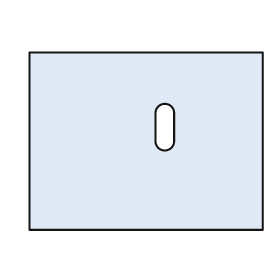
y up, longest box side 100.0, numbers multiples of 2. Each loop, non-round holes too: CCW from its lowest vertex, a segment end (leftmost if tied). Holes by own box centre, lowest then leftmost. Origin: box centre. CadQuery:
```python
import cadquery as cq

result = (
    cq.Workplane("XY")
    .moveTo(-50.0, -38.0)
    .lineTo(50.0, -38.0)
    .lineTo(50.0, 38.0)
    .lineTo(-50.0, 38.0)
    .close()
    .moveTo(4.0, 0.0)
    .threePointArc((8.0, -4.0), (12.0, 0.0))
    .lineTo(12.0, 12.0)
    .threePointArc((8.0, 16.0), (4.0, 12.0))
    .close()
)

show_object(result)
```